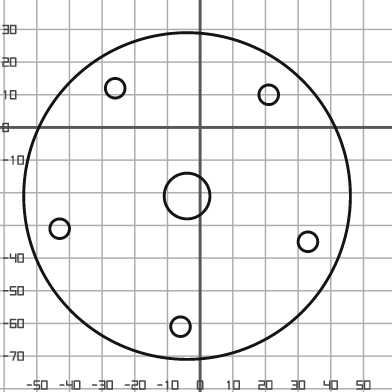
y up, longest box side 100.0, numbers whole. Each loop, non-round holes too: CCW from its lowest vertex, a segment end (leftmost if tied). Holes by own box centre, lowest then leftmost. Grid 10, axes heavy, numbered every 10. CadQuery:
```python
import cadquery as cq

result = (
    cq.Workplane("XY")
    .moveTo(-4.0, -21.0)
    .circle(50.0)
    .moveTo(-6.0, -61.0)
    .circle(3.0)
    .moveTo(33.0, -35.0)
    .circle(3.0)
    .moveTo(-43.0, -31.0)
    .circle(3.0)
    .moveTo(-4.0, -21.0)
    .circle(7.0)
    .moveTo(21.0, 10.0)
    .circle(3.0)
    .moveTo(-26.0, 12.0)
    .circle(3.0)
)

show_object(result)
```